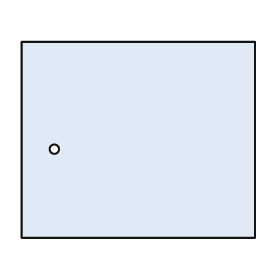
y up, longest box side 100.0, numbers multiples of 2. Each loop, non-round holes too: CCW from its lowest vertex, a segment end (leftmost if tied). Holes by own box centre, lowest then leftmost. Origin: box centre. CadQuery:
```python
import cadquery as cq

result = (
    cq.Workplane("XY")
    .moveTo(-50.0, -42.0)
    .lineTo(50.0, -42.0)
    .lineTo(50.0, 42.0)
    .lineTo(-50.0, 42.0)
    .close()
    .moveTo(-36.0, -4.0)
    .circle(2.0)
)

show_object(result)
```